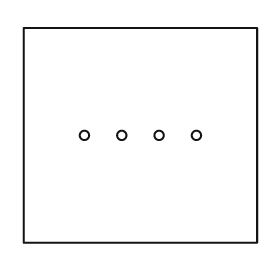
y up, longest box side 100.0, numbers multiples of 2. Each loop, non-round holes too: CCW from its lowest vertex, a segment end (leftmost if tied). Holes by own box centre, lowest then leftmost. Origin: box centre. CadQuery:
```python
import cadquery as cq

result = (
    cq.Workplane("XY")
    .moveTo(-50.0, -46.0)
    .lineTo(50.0, -46.0)
    .lineTo(50.0, 46.0)
    .lineTo(-50.0, 46.0)
    .close()
    .moveTo(-24.0, 0.0)
    .circle(2.0)
    .moveTo(-8.0, 0.0)
    .circle(2.0)
    .moveTo(8.0, 0.0)
    .circle(2.0)
    .moveTo(24.0, 0.0)
    .circle(2.0)
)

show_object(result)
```